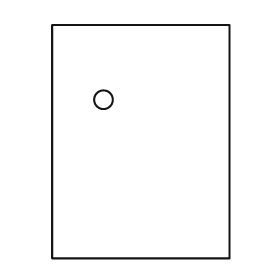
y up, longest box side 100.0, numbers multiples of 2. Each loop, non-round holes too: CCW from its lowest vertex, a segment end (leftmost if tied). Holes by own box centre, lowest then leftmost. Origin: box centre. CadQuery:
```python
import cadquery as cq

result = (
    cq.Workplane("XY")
    .moveTo(-38.0, -50.0)
    .lineTo(38.0, -50.0)
    .lineTo(38.0, 50.0)
    .lineTo(-38.0, 50.0)
    .close()
    .moveTo(-16.0, 18.0)
    .circle(4.0)
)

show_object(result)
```